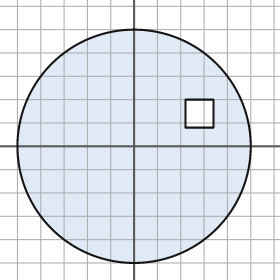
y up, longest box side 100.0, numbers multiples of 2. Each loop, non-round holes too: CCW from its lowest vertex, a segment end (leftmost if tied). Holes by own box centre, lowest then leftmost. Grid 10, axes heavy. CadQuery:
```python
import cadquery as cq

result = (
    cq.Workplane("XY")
    .moveTo(0.0, 0.0)
    .circle(50.0)
    .moveTo(22.0, 8.0)
    .lineTo(34.0, 8.0)
    .lineTo(34.0, 20.0)
    .lineTo(22.0, 20.0)
    .close()
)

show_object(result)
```